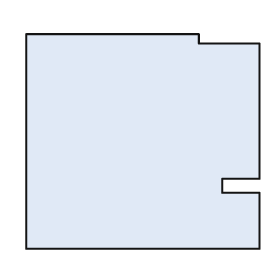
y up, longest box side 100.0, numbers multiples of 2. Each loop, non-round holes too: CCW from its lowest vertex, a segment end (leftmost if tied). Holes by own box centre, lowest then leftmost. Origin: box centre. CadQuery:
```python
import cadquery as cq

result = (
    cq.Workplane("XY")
    .moveTo(-50.0, -46.0)
    .lineTo(50.0, -46.0)
    .lineTo(50.0, -22.0)
    .lineTo(34.0, -22.0)
    .lineTo(34.0, -16.0)
    .lineTo(50.0, -16.0)
    .lineTo(50.0, 42.0)
    .lineTo(24.0, 42.0)
    .lineTo(24.0, 46.0)
    .lineTo(-50.0, 46.0)
    .close()
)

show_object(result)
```